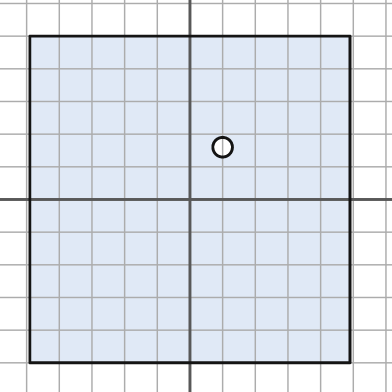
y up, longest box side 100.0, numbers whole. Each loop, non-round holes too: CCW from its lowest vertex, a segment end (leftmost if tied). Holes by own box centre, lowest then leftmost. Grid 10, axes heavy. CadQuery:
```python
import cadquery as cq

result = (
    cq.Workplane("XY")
    .moveTo(-49.0, -50.0)
    .lineTo(49.0, -50.0)
    .lineTo(49.0, 50.0)
    .lineTo(-49.0, 50.0)
    .close()
    .moveTo(10.0, 16.0)
    .circle(3.0)
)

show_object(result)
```